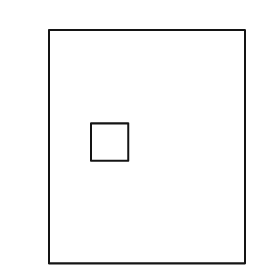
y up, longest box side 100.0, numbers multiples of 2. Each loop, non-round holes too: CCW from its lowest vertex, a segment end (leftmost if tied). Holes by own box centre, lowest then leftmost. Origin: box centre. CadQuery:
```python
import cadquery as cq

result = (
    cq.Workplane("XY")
    .moveTo(-42.0, -50.0)
    .lineTo(42.0, -50.0)
    .lineTo(42.0, 50.0)
    .lineTo(-42.0, 50.0)
    .close()
    .moveTo(-24.0, -6.0)
    .lineTo(-8.0, -6.0)
    .lineTo(-8.0, 10.0)
    .lineTo(-24.0, 10.0)
    .close()
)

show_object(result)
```